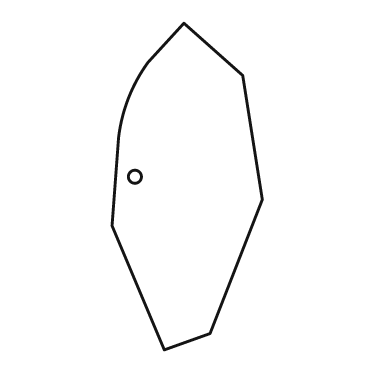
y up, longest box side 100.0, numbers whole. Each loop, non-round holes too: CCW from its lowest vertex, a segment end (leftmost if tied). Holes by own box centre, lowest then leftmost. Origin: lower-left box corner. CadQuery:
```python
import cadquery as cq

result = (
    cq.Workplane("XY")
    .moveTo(16.0, 0.0)
    .lineTo(30.0, 5.0)
    .lineTo(46.0, 46.0)
    .lineTo(40.0, 84.0)
    .lineTo(22.0, 100.0)
    .lineTo(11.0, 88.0)
    .threePointArc((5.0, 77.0), (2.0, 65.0))
    .lineTo(0.0, 38.0)
    .close()
    .moveTo(7.0, 53.0)
    .circle(2.0)
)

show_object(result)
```